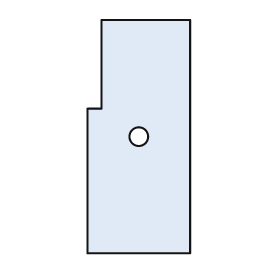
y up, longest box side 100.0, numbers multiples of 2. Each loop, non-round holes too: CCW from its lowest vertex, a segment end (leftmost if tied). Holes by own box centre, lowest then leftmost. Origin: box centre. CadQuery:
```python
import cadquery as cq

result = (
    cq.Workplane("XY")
    .moveTo(-22.0, -50.0)
    .lineTo(22.0, -50.0)
    .lineTo(22.0, 50.0)
    .lineTo(-16.0, 50.0)
    .lineTo(-16.0, 12.0)
    .lineTo(-22.0, 12.0)
    .close()
    .moveTo(0.0, 0.0)
    .circle(4.0)
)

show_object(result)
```